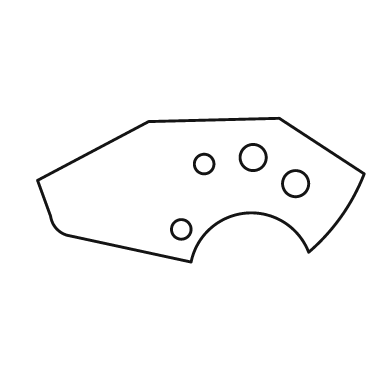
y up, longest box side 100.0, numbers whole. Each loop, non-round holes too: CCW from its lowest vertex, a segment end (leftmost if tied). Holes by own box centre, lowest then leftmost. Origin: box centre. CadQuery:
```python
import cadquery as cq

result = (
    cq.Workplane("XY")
    .moveTo(-3.0, -22.0)
    .threePointArc((14.0, -7.0), (33.0, -19.0))
    .threePointArc((43.0, -8.0), (50.0, 5.0))
    .lineTo(24.0, 22.0)
    .lineTo(-16.0, 21.0)
    .lineTo(-50.0, 3.0)
    .lineTo(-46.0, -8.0)
    .threePointArc((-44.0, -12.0), (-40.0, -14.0))
    .close()
    .moveTo(-6.0, -12.0)
    .circle(3.0)
    .moveTo(29.0, 2.0)
    .circle(4.0)
    .moveTo(1.0, 8.0)
    .circle(3.0)
    .moveTo(16.0, 10.0)
    .circle(4.0)
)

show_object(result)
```